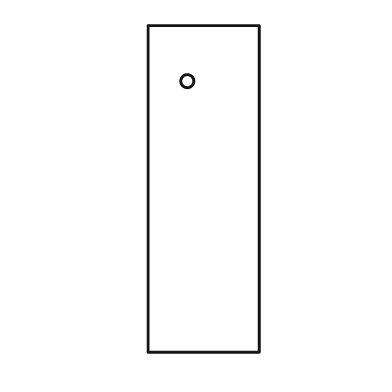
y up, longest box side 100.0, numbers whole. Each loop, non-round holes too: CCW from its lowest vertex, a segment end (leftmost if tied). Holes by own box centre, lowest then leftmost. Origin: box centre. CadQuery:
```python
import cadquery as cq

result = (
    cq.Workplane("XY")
    .moveTo(-17.0, -50.0)
    .lineTo(17.0, -50.0)
    .lineTo(17.0, 50.0)
    .lineTo(-17.0, 50.0)
    .close()
    .moveTo(-5.0, 33.0)
    .circle(2.0)
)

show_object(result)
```